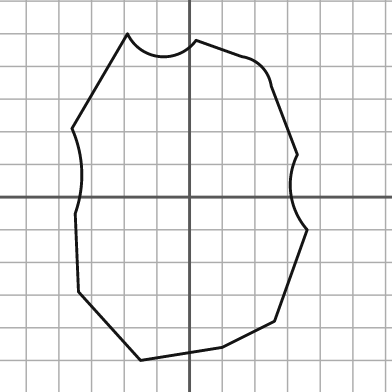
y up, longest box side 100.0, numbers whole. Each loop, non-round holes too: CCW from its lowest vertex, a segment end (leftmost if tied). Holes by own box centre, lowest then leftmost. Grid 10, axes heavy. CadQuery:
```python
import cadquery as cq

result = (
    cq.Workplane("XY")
    .moveTo(-15.0, -50.0)
    .lineTo(10.0, -46.0)
    .lineTo(26.0, -38.0)
    .lineTo(36.0, -10.0)
    .threePointArc((31.0, 1.0), (33.0, 13.0))
    .lineTo(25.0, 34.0)
    .threePointArc((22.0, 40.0), (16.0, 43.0))
    .lineTo(2.0, 48.0)
    .threePointArc((-9.0, 43.0), (-19.0, 50.0))
    .lineTo(-36.0, 21.0)
    .threePointArc((-33.0, 8.0), (-35.0, -5.0))
    .lineTo(-34.0, -29.0)
    .close()
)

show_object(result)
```